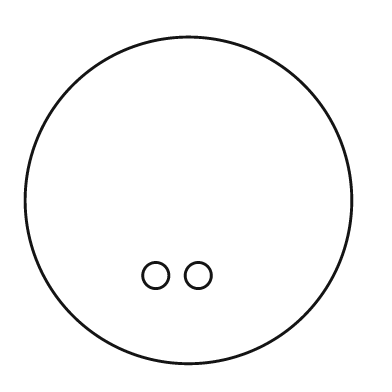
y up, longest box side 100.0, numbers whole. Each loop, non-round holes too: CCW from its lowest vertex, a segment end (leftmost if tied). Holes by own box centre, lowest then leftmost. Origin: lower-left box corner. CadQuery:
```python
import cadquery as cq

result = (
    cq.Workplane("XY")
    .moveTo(50.0, 50.0)
    .circle(50.0)
    .moveTo(40.0, 27.0)
    .circle(4.0)
    .moveTo(53.0, 27.0)
    .circle(4.0)
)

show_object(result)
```